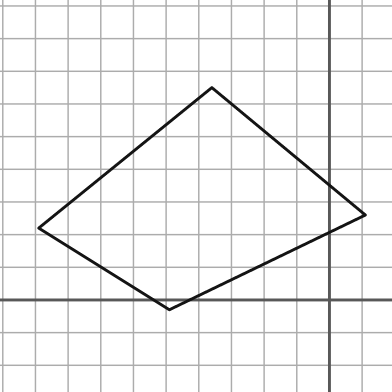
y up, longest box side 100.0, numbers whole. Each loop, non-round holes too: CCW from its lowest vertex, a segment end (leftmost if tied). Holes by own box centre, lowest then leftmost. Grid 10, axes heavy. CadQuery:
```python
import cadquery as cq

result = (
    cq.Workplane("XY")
    .moveTo(-49.0, -3.0)
    .lineTo(11.0, 26.0)
    .lineTo(-36.0, 65.0)
    .lineTo(-89.0, 22.0)
    .close()
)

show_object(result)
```